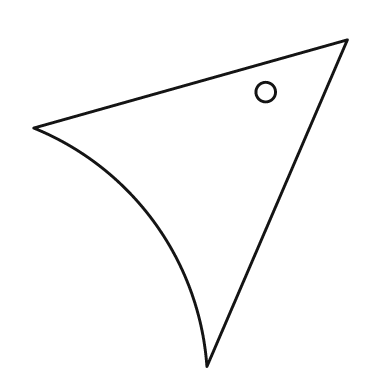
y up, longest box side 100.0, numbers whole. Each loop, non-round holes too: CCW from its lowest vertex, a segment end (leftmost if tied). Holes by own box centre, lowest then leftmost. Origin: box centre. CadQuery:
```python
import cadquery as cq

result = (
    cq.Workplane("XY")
    .moveTo(5.0, -50.0)
    .lineTo(48.0, 50.0)
    .lineTo(-48.0, 23.0)
    .threePointArc((-11.0, -6.0), (5.0, -50.0))
    .close()
    .moveTo(23.0, 34.0)
    .circle(3.0)
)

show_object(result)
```